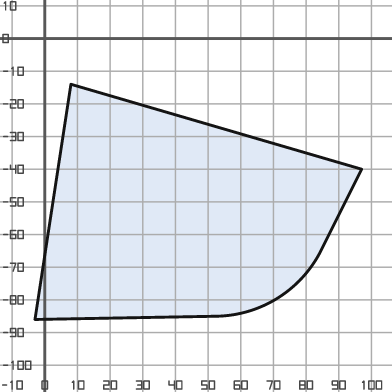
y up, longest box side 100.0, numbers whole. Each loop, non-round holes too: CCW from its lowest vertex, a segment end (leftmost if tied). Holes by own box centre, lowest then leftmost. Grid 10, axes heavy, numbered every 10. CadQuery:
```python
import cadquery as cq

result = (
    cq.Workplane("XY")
    .moveTo(-3.0, -86.0)
    .lineTo(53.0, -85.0)
    .threePointArc((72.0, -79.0), (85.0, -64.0))
    .lineTo(97.0, -40.0)
    .lineTo(8.0, -14.0)
    .close()
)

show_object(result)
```